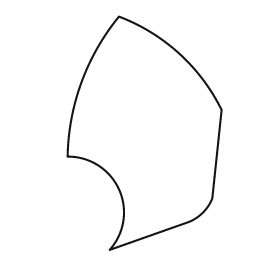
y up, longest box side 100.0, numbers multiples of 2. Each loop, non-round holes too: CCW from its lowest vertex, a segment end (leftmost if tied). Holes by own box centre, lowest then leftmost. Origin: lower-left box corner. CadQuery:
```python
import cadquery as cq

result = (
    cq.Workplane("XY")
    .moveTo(18.0, 0.0)
    .lineTo(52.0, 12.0)
    .threePointArc((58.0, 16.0), (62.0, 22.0))
    .lineTo(66.0, 60.0)
    .threePointArc((48.0, 84.0), (22.0, 100.0))
    .threePointArc((6.0, 72.0), (0.0, 40.0))
    .threePointArc((22.0, 26.0), (18.0, 0.0))
    .close()
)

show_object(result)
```